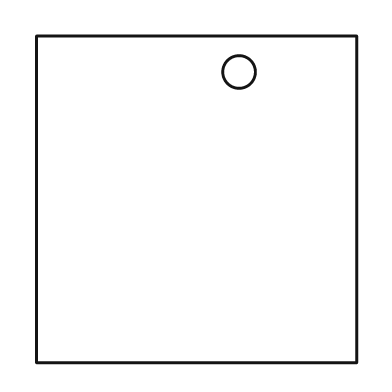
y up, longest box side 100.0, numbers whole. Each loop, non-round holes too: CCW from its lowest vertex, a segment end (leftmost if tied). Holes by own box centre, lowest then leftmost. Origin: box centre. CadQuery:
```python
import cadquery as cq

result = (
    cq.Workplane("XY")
    .moveTo(-49.0, -50.0)
    .lineTo(49.0, -50.0)
    .lineTo(49.0, 50.0)
    .lineTo(-49.0, 50.0)
    .close()
    .moveTo(13.0, 39.0)
    .circle(5.0)
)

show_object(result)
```